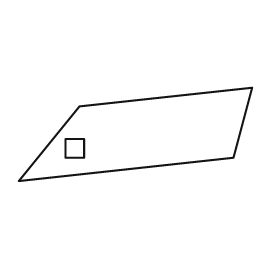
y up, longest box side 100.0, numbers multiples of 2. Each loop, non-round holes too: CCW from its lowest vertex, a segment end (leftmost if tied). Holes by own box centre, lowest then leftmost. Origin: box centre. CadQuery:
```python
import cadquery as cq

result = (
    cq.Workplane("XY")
    .moveTo(-50.0, -20.0)
    .lineTo(42.0, -10.0)
    .lineTo(50.0, 20.0)
    .lineTo(-24.0, 12.0)
    .close()
    .moveTo(-30.0, -10.0)
    .lineTo(-22.0, -10.0)
    .lineTo(-22.0, -2.0)
    .lineTo(-30.0, -2.0)
    .close()
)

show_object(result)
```